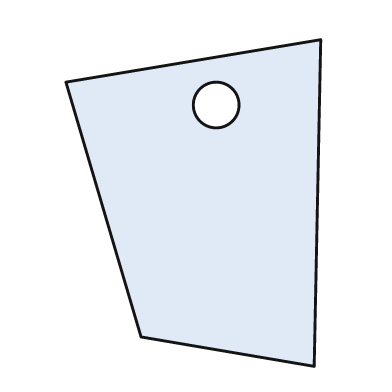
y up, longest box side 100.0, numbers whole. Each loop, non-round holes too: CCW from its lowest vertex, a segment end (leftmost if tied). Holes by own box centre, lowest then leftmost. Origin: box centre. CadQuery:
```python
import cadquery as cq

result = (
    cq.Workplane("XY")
    .moveTo(37.0, -50.0)
    .lineTo(39.0, 50.0)
    .lineTo(-39.0, 37.0)
    .lineTo(-16.0, -41.0)
    .close()
    .moveTo(7.0, 30.0)
    .circle(7.0)
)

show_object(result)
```